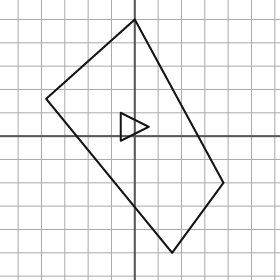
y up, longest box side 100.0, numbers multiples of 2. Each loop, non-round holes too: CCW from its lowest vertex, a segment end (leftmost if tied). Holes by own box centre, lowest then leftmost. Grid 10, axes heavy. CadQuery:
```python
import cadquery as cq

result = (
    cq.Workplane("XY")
    .moveTo(16.0, -50.0)
    .lineTo(38.0, -20.0)
    .lineTo(0.0, 50.0)
    .lineTo(-38.0, 16.0)
    .close()
    .moveTo(-6.0, -2.0)
    .lineTo(6.0, 4.0)
    .lineTo(-6.0, 10.0)
    .close()
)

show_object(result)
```